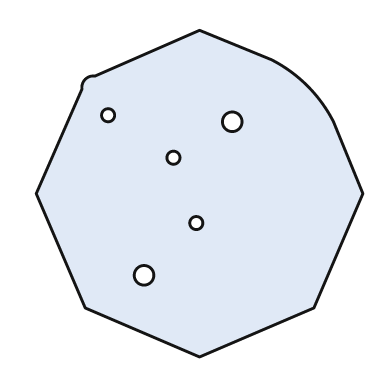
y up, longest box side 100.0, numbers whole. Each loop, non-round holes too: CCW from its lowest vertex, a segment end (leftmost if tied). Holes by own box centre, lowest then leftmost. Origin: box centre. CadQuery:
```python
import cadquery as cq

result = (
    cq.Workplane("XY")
    .moveTo(0.0, -50.0)
    .lineTo(35.0, -35.0)
    .lineTo(50.0, 0.0)
    .lineTo(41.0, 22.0)
    .threePointArc((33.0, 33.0), (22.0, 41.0))
    .lineTo(0.0, 50.0)
    .lineTo(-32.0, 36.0)
    .threePointArc((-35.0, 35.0), (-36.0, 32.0))
    .lineTo(-50.0, 0.0)
    .lineTo(-35.0, -35.0)
    .close()
    .moveTo(-17.0, -25.0)
    .circle(3.0)
    .moveTo(-1.0, -9.0)
    .circle(2.0)
    .moveTo(-8.0, 11.0)
    .circle(2.0)
    .moveTo(10.0, 22.0)
    .circle(3.0)
    .moveTo(-28.0, 24.0)
    .circle(2.0)
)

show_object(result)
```